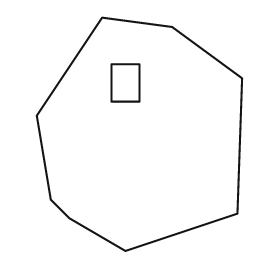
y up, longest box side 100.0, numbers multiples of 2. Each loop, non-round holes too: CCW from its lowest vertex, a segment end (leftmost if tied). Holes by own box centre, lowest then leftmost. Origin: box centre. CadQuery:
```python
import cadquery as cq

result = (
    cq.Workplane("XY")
    .moveTo(-6.0, -50.0)
    .lineTo(42.0, -34.0)
    .lineTo(44.0, 24.0)
    .lineTo(14.0, 46.0)
    .lineTo(-16.0, 50.0)
    .lineTo(-44.0, 8.0)
    .lineTo(-38.0, -28.0)
    .lineTo(-30.0, -36.0)
    .close()
    .moveTo(-12.0, 14.0)
    .lineTo(0.0, 14.0)
    .lineTo(0.0, 30.0)
    .lineTo(-12.0, 30.0)
    .close()
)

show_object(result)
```